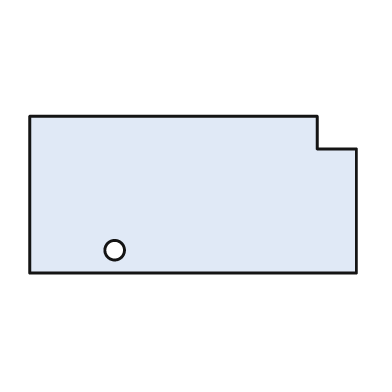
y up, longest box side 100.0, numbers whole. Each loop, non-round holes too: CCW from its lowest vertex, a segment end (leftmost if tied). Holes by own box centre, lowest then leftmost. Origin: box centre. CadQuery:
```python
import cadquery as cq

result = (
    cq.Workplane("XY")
    .moveTo(-50.0, -24.0)
    .lineTo(50.0, -24.0)
    .lineTo(50.0, 14.0)
    .lineTo(38.0, 14.0)
    .lineTo(38.0, 24.0)
    .lineTo(-50.0, 24.0)
    .close()
    .moveTo(-24.0, -17.0)
    .circle(3.0)
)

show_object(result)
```